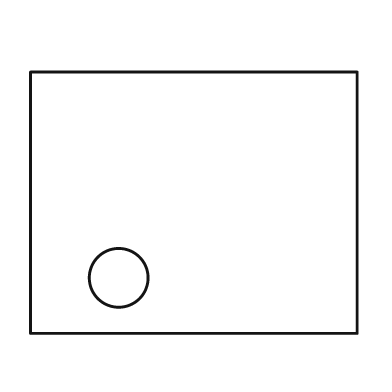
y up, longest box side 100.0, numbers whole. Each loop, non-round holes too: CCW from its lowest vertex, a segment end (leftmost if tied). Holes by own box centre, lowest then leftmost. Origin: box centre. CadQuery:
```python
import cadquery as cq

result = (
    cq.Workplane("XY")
    .moveTo(-50.0, -40.0)
    .lineTo(50.0, -40.0)
    .lineTo(50.0, 40.0)
    .lineTo(-50.0, 40.0)
    .close()
    .moveTo(-23.0, -23.0)
    .circle(9.0)
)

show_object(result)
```